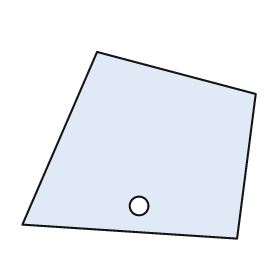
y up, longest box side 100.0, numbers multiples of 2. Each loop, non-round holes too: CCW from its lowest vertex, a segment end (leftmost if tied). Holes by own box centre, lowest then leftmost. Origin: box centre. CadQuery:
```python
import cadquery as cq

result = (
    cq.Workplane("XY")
    .moveTo(42.0, -40.0)
    .lineTo(50.0, 22.0)
    .lineTo(-18.0, 40.0)
    .lineTo(-50.0, -34.0)
    .close()
    .moveTo(0.0, -26.0)
    .circle(4.0)
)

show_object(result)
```